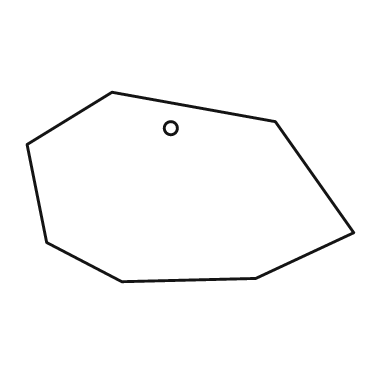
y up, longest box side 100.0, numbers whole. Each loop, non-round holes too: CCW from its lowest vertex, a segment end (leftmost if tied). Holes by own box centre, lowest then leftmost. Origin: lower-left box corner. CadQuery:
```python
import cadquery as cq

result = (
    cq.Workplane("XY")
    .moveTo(29.0, 0.0)
    .lineTo(70.0, 1.0)
    .lineTo(100.0, 15.0)
    .lineTo(76.0, 49.0)
    .lineTo(26.0, 58.0)
    .lineTo(0.0, 42.0)
    .lineTo(6.0, 12.0)
    .close()
    .moveTo(44.0, 47.0)
    .circle(2.0)
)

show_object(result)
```